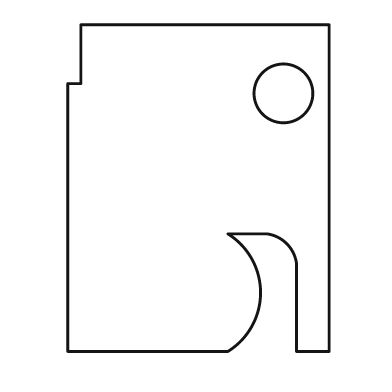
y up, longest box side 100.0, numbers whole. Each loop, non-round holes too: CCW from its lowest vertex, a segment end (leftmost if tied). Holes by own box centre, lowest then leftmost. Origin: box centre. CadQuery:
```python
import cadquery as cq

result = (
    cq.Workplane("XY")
    .moveTo(-40.0, -50.0)
    .lineTo(9.0, -50.0)
    .threePointArc((19.0, -32.0), (9.0, -14.0))
    .lineTo(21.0, -14.0)
    .threePointArc((27.0, -17.0), (30.0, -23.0))
    .lineTo(30.0, -50.0)
    .lineTo(40.0, -50.0)
    .lineTo(40.0, 50.0)
    .lineTo(-36.0, 50.0)
    .lineTo(-36.0, 32.0)
    .lineTo(-40.0, 32.0)
    .close()
    .moveTo(26.0, 29.0)
    .circle(9.0)
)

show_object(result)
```